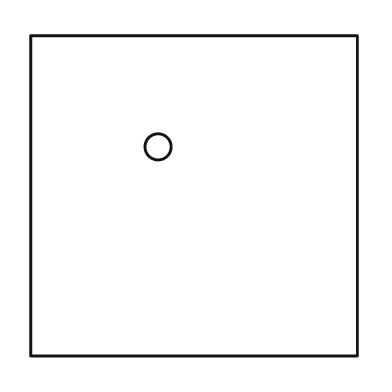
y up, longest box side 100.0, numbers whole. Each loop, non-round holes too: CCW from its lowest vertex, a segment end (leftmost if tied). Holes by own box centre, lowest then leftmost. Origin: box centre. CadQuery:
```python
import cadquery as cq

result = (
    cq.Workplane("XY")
    .moveTo(-50.0, -49.0)
    .lineTo(50.0, -49.0)
    .lineTo(50.0, 49.0)
    .lineTo(-50.0, 49.0)
    .close()
    .moveTo(-11.0, 15.0)
    .circle(4.0)
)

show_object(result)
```